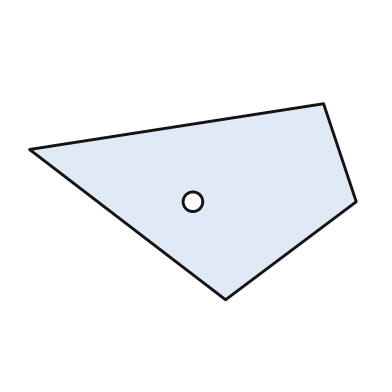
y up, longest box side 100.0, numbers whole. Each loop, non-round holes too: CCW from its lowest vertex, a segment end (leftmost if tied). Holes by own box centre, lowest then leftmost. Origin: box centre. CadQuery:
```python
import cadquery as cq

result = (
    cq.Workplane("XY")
    .moveTo(10.0, -30.0)
    .lineTo(50.0, 0.0)
    .lineTo(40.0, 30.0)
    .lineTo(-50.0, 16.0)
    .close()
    .moveTo(0.0, 0.0)
    .circle(3.0)
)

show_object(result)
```